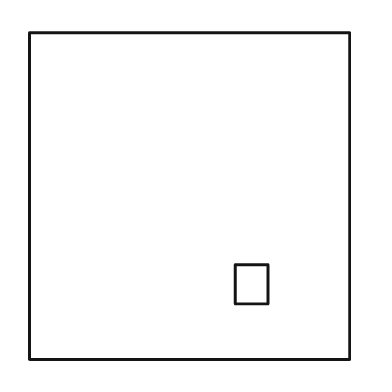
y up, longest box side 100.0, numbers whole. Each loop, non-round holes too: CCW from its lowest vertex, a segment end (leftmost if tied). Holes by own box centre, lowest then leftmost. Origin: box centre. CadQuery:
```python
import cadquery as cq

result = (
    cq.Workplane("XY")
    .moveTo(-49.0, -50.0)
    .lineTo(49.0, -50.0)
    .lineTo(49.0, 50.0)
    .lineTo(-49.0, 50.0)
    .close()
    .moveTo(14.0, -33.0)
    .lineTo(24.0, -33.0)
    .lineTo(24.0, -21.0)
    .lineTo(14.0, -21.0)
    .close()
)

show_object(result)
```